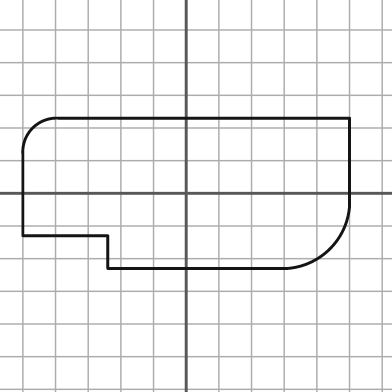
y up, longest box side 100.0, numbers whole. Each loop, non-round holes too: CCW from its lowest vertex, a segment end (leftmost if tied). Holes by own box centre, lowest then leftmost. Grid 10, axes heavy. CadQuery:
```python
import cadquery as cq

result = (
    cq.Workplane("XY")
    .moveTo(-24.0, -23.0)
    .lineTo(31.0, -23.0)
    .threePointArc((44.0, -17.0), (50.0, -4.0))
    .lineTo(50.0, 23.0)
    .lineTo(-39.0, 23.0)
    .threePointArc((-47.0, 20.0), (-50.0, 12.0))
    .lineTo(-50.0, -13.0)
    .lineTo(-24.0, -13.0)
    .close()
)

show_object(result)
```